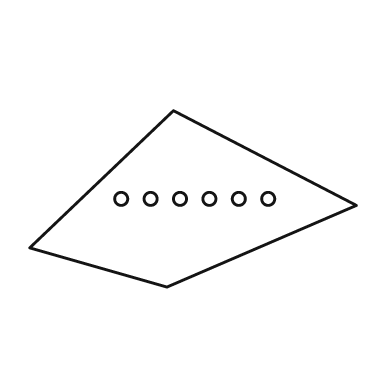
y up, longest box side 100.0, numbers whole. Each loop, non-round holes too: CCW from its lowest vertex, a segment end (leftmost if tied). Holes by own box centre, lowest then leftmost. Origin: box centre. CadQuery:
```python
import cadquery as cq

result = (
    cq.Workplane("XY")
    .moveTo(-8.0, -27.0)
    .lineTo(50.0, -2.0)
    .lineTo(-6.0, 27.0)
    .lineTo(-50.0, -15.0)
    .close()
    .moveTo(-22.0, 0.0)
    .circle(2.0)
    .moveTo(-13.0, 0.0)
    .circle(2.0)
    .moveTo(-4.0, 0.0)
    .circle(2.0)
    .moveTo(5.0, 0.0)
    .circle(2.0)
    .moveTo(14.0, 0.0)
    .circle(2.0)
    .moveTo(23.0, 0.0)
    .circle(2.0)
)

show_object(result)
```